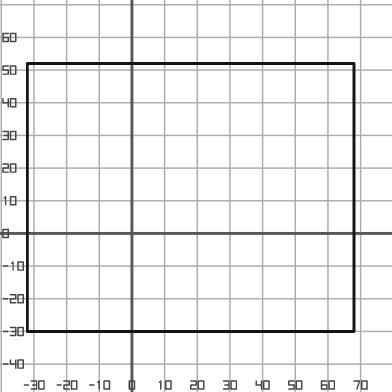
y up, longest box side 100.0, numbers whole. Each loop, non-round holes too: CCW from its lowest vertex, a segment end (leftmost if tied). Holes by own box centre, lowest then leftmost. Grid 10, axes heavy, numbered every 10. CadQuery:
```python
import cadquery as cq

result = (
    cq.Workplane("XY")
    .moveTo(-32.0, -30.0)
    .lineTo(68.0, -30.0)
    .lineTo(68.0, 52.0)
    .lineTo(-32.0, 52.0)
    .close()
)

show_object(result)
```